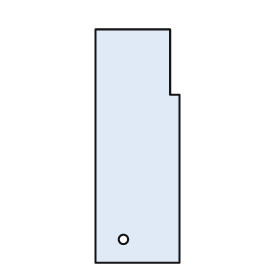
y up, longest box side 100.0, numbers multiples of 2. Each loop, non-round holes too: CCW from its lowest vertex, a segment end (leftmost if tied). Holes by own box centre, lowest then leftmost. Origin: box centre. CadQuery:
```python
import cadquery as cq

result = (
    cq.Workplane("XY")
    .moveTo(-18.0, -50.0)
    .lineTo(18.0, -50.0)
    .lineTo(18.0, 22.0)
    .lineTo(14.0, 22.0)
    .lineTo(14.0, 50.0)
    .lineTo(-18.0, 50.0)
    .close()
    .moveTo(-6.0, -40.0)
    .circle(2.0)
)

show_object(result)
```